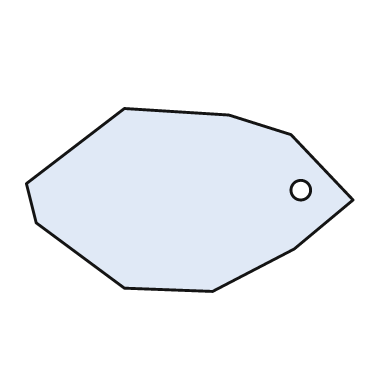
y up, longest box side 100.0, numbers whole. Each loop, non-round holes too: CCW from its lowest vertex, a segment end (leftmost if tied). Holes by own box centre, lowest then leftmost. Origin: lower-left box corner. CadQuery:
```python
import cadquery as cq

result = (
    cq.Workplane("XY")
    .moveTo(57.0, 0.0)
    .lineTo(82.0, 13.0)
    .lineTo(100.0, 28.0)
    .lineTo(81.0, 48.0)
    .lineTo(62.0, 54.0)
    .lineTo(30.0, 56.0)
    .lineTo(0.0, 33.0)
    .lineTo(3.0, 21.0)
    .lineTo(30.0, 1.0)
    .close()
    .moveTo(84.0, 31.0)
    .circle(3.0)
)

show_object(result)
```